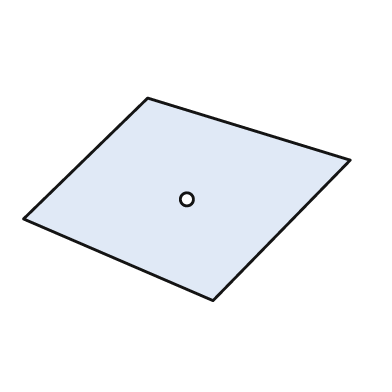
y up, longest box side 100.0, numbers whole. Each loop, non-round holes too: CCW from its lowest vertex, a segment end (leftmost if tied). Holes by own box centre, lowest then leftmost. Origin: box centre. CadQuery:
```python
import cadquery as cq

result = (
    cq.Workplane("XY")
    .moveTo(8.0, -31.0)
    .lineTo(50.0, 12.0)
    .lineTo(-12.0, 31.0)
    .lineTo(-50.0, -6.0)
    .close()
    .moveTo(0.0, 0.0)
    .circle(2.0)
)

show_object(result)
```